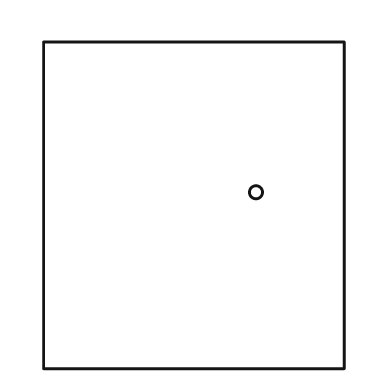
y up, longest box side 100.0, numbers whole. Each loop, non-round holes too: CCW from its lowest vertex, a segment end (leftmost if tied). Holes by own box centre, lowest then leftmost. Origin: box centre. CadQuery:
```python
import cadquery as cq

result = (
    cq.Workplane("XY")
    .moveTo(-46.0, -50.0)
    .lineTo(46.0, -50.0)
    .lineTo(46.0, 50.0)
    .lineTo(-46.0, 50.0)
    .close()
    .moveTo(19.0, 4.0)
    .circle(2.0)
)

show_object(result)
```